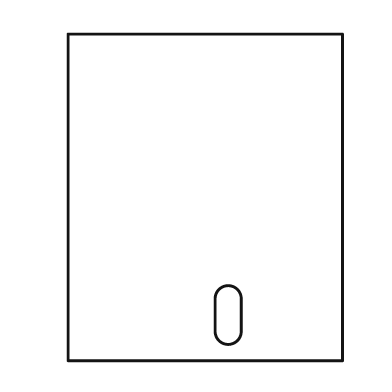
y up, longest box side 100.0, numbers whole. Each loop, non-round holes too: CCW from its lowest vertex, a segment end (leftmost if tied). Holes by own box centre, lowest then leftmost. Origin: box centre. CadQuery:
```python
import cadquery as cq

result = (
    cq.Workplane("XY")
    .moveTo(-42.0, -50.0)
    .lineTo(42.0, -50.0)
    .lineTo(42.0, 50.0)
    .lineTo(-42.0, 50.0)
    .close()
    .moveTo(3.0, -41.0)
    .threePointArc((7.0, -45.0), (11.0, -41.0))
    .lineTo(11.0, -31.0)
    .threePointArc((7.0, -27.0), (3.0, -31.0))
    .close()
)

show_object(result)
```